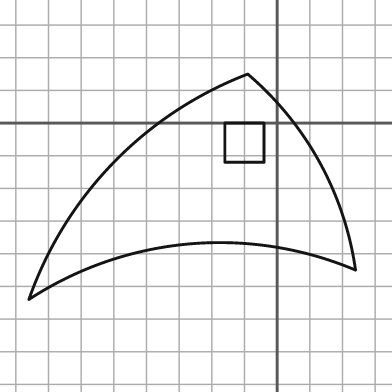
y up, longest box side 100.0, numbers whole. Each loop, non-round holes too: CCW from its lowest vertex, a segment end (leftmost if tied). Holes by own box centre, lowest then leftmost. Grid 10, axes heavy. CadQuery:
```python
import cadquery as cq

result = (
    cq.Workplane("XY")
    .moveTo(-76.0, -54.0)
    .threePointArc((-27.0, -37.0), (24.0, -45.0))
    .threePointArc((13.0, -12.0), (-9.0, 15.0))
    .threePointArc((-50.0, -12.0), (-76.0, -54.0))
    .close()
    .moveTo(-16.0, -12.0)
    .lineTo(-4.0, -12.0)
    .lineTo(-4.0, 0.0)
    .lineTo(-16.0, 0.0)
    .close()
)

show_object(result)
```